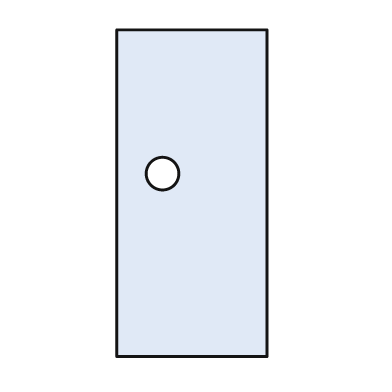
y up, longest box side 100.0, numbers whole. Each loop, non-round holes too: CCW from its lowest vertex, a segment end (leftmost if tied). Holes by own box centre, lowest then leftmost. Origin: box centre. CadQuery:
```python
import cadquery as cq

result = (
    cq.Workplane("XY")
    .moveTo(-23.0, -50.0)
    .lineTo(23.0, -50.0)
    .lineTo(23.0, 50.0)
    .lineTo(-23.0, 50.0)
    .close()
    .moveTo(-9.0, 6.0)
    .circle(5.0)
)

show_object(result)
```